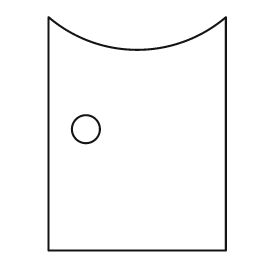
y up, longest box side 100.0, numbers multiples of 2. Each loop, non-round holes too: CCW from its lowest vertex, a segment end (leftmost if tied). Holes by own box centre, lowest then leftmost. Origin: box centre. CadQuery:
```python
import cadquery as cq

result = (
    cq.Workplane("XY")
    .moveTo(-38.0, -50.0)
    .lineTo(38.0, -50.0)
    .lineTo(38.0, 50.0)
    .threePointArc((0.0, 36.0), (-38.0, 50.0))
    .close()
    .moveTo(-22.0, 2.0)
    .circle(6.0)
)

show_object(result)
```